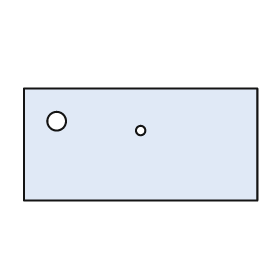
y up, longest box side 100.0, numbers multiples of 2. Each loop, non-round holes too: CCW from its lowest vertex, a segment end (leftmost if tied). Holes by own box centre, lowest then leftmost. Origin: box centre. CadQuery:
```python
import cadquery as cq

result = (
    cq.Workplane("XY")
    .moveTo(-50.0, -24.0)
    .lineTo(50.0, -24.0)
    .lineTo(50.0, 24.0)
    .lineTo(-50.0, 24.0)
    .close()
    .moveTo(0.0, 6.0)
    .circle(2.0)
    .moveTo(-36.0, 10.0)
    .circle(4.0)
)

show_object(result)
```